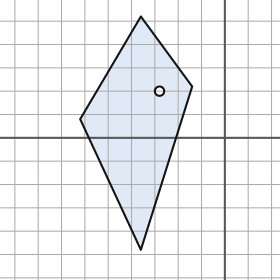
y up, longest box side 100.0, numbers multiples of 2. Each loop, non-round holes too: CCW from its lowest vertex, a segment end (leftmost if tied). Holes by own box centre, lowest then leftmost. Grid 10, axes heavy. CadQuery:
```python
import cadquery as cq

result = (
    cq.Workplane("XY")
    .moveTo(-36.0, -48.0)
    .lineTo(-14.0, 22.0)
    .lineTo(-36.0, 52.0)
    .lineTo(-62.0, 8.0)
    .close()
    .moveTo(-28.0, 20.0)
    .circle(2.0)
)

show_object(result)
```